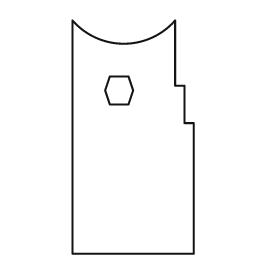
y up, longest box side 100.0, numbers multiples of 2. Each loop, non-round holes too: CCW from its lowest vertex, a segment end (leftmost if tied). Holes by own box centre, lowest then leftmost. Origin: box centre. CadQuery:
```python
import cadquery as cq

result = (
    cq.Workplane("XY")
    .moveTo(-26.0, -50.0)
    .lineTo(26.0, -50.0)
    .lineTo(26.0, 6.0)
    .lineTo(22.0, 6.0)
    .lineTo(22.0, 22.0)
    .lineTo(18.0, 22.0)
    .lineTo(18.0, 50.0)
    .threePointArc((-4.0, 40.0), (-26.0, 50.0))
    .close()
    .moveTo(-10.0, 14.0)
    .lineTo(-2.0, 14.0)
    .lineTo(0.0, 20.0)
    .lineTo(-2.0, 26.0)
    .lineTo(-10.0, 26.0)
    .lineTo(-12.0, 20.0)
    .close()
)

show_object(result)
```